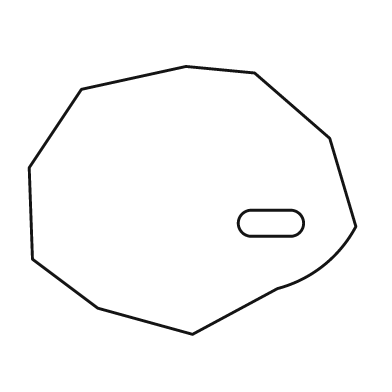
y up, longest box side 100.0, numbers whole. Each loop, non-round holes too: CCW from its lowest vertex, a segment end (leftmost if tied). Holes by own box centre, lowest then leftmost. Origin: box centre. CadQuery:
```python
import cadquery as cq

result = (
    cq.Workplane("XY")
    .moveTo(0.0, -41.0)
    .lineTo(26.0, -27.0)
    .threePointArc((40.0, -20.0), (50.0, -8.0))
    .lineTo(42.0, 19.0)
    .lineTo(19.0, 39.0)
    .lineTo(-2.0, 41.0)
    .lineTo(-34.0, 34.0)
    .lineTo(-50.0, 10.0)
    .lineTo(-49.0, -18.0)
    .lineTo(-29.0, -33.0)
    .close()
    .moveTo(18.0, -11.0)
    .lineTo(30.0, -11.0)
    .threePointArc((34.0, -7.0), (30.0, -3.0))
    .lineTo(18.0, -3.0)
    .threePointArc((14.0, -7.0), (18.0, -11.0))
    .close()
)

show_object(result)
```